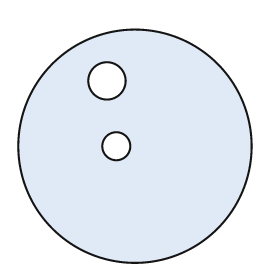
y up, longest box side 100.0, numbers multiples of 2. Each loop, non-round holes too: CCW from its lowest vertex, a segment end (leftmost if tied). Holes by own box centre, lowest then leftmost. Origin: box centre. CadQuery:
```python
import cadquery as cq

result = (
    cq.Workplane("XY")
    .moveTo(0.0, 0.0)
    .circle(50.0)
    .moveTo(-8.0, 0.0)
    .circle(6.0)
    .moveTo(-12.0, 28.0)
    .circle(8.0)
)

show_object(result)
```